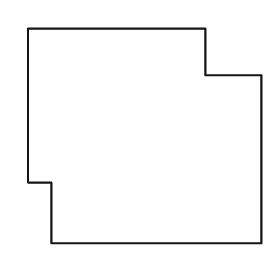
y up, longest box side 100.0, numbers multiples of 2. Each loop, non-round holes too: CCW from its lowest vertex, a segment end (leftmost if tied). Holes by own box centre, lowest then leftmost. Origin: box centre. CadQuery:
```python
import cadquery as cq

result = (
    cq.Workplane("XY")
    .moveTo(-40.0, -46.0)
    .lineTo(50.0, -46.0)
    .lineTo(50.0, 26.0)
    .lineTo(26.0, 26.0)
    .lineTo(26.0, 46.0)
    .lineTo(-50.0, 46.0)
    .lineTo(-50.0, -20.0)
    .lineTo(-40.0, -20.0)
    .close()
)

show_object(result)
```